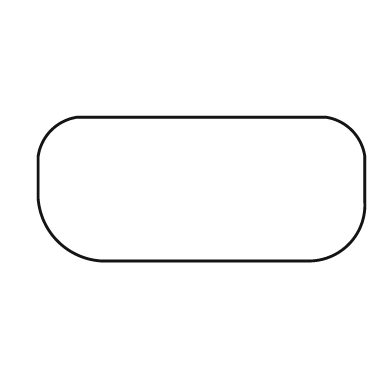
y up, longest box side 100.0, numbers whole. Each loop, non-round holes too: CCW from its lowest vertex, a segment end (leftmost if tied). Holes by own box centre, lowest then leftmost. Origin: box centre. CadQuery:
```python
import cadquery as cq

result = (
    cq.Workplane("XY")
    .moveTo(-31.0, -22.0)
    .lineTo(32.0, -22.0)
    .threePointArc((45.0, -17.0), (50.0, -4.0))
    .lineTo(50.0, 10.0)
    .threePointArc((46.0, 18.0), (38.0, 22.0))
    .lineTo(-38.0, 22.0)
    .threePointArc((-46.0, 18.0), (-50.0, 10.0))
    .lineTo(-50.0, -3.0)
    .threePointArc((-44.0, -16.0), (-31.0, -22.0))
    .close()
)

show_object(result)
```